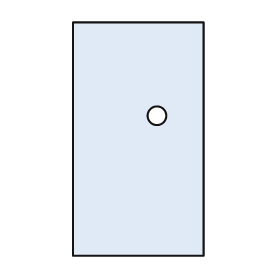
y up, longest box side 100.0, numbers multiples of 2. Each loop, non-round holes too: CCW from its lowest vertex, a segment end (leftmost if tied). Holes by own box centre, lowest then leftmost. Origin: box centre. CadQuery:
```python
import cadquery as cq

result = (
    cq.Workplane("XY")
    .moveTo(-28.0, -50.0)
    .lineTo(28.0, -50.0)
    .lineTo(28.0, 50.0)
    .lineTo(-28.0, 50.0)
    .close()
    .moveTo(8.0, 10.0)
    .circle(4.0)
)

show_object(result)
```